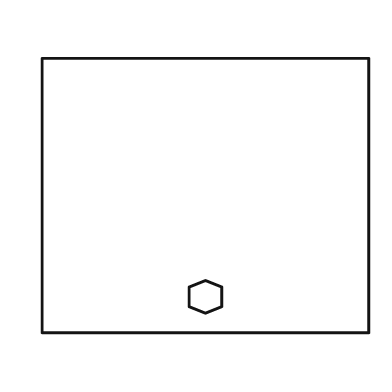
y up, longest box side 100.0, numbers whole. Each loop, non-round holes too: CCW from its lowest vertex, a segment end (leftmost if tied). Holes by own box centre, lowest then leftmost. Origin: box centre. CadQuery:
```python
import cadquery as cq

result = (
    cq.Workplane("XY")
    .moveTo(-50.0, -42.0)
    .lineTo(50.0, -42.0)
    .lineTo(50.0, 42.0)
    .lineTo(-50.0, 42.0)
    .close()
    .moveTo(0.0, -36.0)
    .lineTo(5.0, -34.0)
    .lineTo(5.0, -28.0)
    .lineTo(0.0, -26.0)
    .lineTo(-5.0, -28.0)
    .lineTo(-5.0, -34.0)
    .close()
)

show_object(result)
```